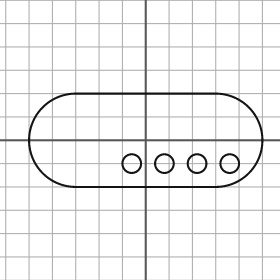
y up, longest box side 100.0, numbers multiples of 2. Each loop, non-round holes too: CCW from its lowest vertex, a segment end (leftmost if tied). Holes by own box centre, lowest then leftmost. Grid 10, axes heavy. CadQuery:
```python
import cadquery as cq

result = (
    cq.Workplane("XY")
    .moveTo(-30.0, -20.0)
    .lineTo(30.0, -20.0)
    .threePointArc((50.0, 0.0), (30.0, 20.0))
    .lineTo(-30.0, 20.0)
    .threePointArc((-50.0, 0.0), (-30.0, -20.0))
    .close()
    .moveTo(-6.0, -10.0)
    .circle(4.0)
    .moveTo(8.0, -10.0)
    .circle(4.0)
    .moveTo(22.0, -10.0)
    .circle(4.0)
    .moveTo(36.0, -10.0)
    .circle(4.0)
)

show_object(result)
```